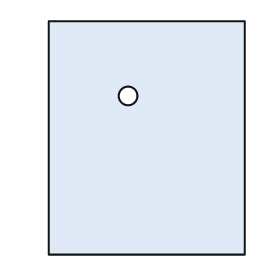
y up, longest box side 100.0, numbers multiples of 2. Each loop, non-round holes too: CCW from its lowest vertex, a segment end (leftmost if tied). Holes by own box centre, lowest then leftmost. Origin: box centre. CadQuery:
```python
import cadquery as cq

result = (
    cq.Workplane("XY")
    .moveTo(-42.0, -50.0)
    .lineTo(42.0, -50.0)
    .lineTo(42.0, 50.0)
    .lineTo(-42.0, 50.0)
    .close()
    .moveTo(-8.0, 18.0)
    .circle(4.0)
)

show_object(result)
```